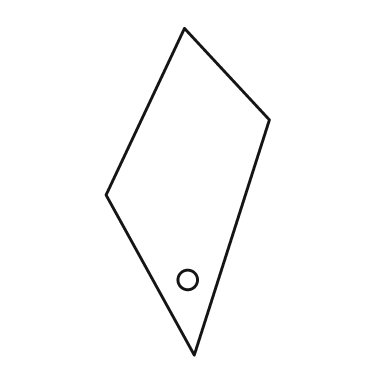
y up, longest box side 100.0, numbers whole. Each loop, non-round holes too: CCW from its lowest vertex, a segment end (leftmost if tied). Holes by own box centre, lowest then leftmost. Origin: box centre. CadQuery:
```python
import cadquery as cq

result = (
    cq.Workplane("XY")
    .moveTo(2.0, -50.0)
    .lineTo(25.0, 22.0)
    .lineTo(-1.0, 50.0)
    .lineTo(-25.0, -1.0)
    .close()
    .moveTo(0.0, -27.0)
    .circle(3.0)
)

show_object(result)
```